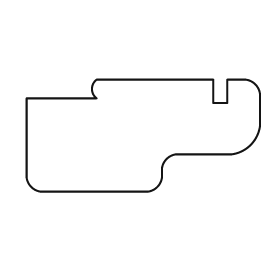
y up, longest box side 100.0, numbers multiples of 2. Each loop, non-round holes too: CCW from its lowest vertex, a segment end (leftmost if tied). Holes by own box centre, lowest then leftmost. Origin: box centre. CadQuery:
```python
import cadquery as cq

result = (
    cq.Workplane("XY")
    .moveTo(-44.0, -24.0)
    .lineTo(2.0, -24.0)
    .threePointArc((6.0, -22.0), (8.0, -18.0))
    .lineTo(8.0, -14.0)
    .threePointArc((10.0, -10.0), (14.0, -8.0))
    .lineTo(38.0, -8.0)
    .threePointArc((46.0, -4.0), (50.0, 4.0))
    .lineTo(50.0, 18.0)
    .threePointArc((48.0, 22.0), (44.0, 24.0))
    .lineTo(36.0, 24.0)
    .lineTo(36.0, 14.0)
    .lineTo(30.0, 14.0)
    .lineTo(30.0, 24.0)
    .lineTo(-20.0, 24.0)
    .threePointArc((-22.0, 20.0), (-20.0, 16.0))
    .lineTo(-50.0, 16.0)
    .lineTo(-50.0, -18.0)
    .threePointArc((-48.0, -22.0), (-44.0, -24.0))
    .close()
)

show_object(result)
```